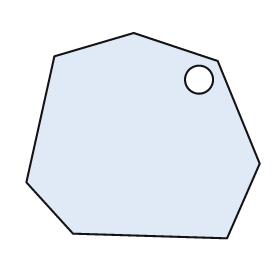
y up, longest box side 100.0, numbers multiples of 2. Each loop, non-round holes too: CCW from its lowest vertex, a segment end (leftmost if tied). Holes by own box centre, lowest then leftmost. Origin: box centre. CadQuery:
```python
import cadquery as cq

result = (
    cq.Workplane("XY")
    .moveTo(36.0, -44.0)
    .lineTo(50.0, -12.0)
    .lineTo(32.0, 32.0)
    .lineTo(-4.0, 44.0)
    .lineTo(-38.0, 34.0)
    .lineTo(-50.0, -20.0)
    .lineTo(-30.0, -42.0)
    .close()
    .moveTo(24.0, 24.0)
    .circle(6.0)
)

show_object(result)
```